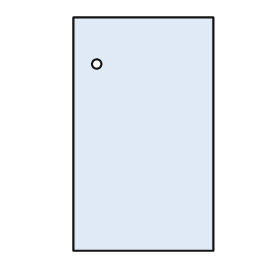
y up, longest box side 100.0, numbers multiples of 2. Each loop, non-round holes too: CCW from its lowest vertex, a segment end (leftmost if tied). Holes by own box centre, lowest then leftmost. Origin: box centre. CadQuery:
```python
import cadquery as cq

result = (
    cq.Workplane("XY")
    .moveTo(-30.0, -50.0)
    .lineTo(30.0, -50.0)
    .lineTo(30.0, 50.0)
    .lineTo(-30.0, 50.0)
    .close()
    .moveTo(-20.0, 30.0)
    .circle(2.0)
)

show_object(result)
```